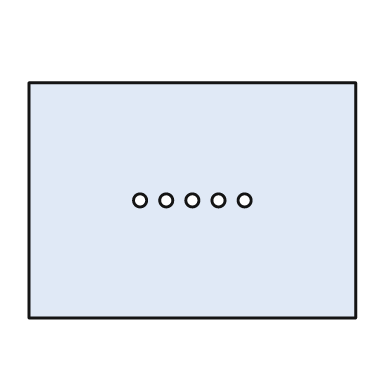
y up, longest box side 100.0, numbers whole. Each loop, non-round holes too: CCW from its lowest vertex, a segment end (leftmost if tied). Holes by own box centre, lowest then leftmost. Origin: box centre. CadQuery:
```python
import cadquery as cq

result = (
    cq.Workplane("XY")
    .moveTo(-50.0, -36.0)
    .lineTo(50.0, -36.0)
    .lineTo(50.0, 36.0)
    .lineTo(-50.0, 36.0)
    .close()
    .moveTo(-16.0, 0.0)
    .circle(2.0)
    .moveTo(-8.0, 0.0)
    .circle(2.0)
    .moveTo(0.0, 0.0)
    .circle(2.0)
    .moveTo(8.0, 0.0)
    .circle(2.0)
    .moveTo(16.0, 0.0)
    .circle(2.0)
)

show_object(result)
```